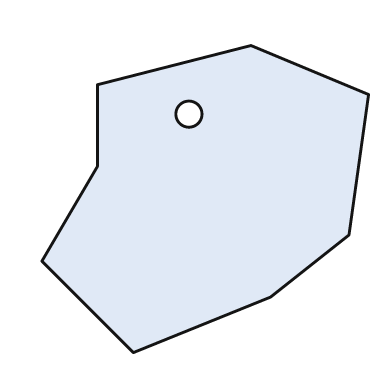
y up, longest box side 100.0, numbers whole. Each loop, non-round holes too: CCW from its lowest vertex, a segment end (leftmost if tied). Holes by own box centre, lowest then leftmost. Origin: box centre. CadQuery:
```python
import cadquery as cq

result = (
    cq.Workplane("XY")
    .moveTo(-22.0, -47.0)
    .lineTo(20.0, -30.0)
    .lineTo(44.0, -11.0)
    .lineTo(50.0, 32.0)
    .lineTo(14.0, 47.0)
    .lineTo(-33.0, 35.0)
    .lineTo(-33.0, 10.0)
    .lineTo(-50.0, -19.0)
    .close()
    .moveTo(-5.0, 26.0)
    .circle(4.0)
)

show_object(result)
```